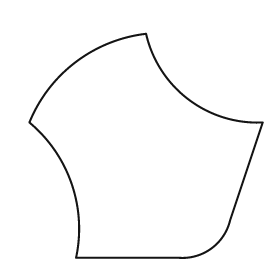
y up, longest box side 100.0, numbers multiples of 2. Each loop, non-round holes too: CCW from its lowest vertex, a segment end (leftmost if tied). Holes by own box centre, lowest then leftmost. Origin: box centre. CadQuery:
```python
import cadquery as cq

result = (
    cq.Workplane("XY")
    .moveTo(-30.0, -48.0)
    .lineTo(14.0, -48.0)
    .threePointArc((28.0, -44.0), (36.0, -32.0))
    .lineTo(50.0, 10.0)
    .threePointArc((18.0, 20.0), (0.0, 48.0))
    .threePointArc((-30.0, 36.0), (-50.0, 10.0))
    .threePointArc((-32.0, -16.0), (-30.0, -48.0))
    .close()
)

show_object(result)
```